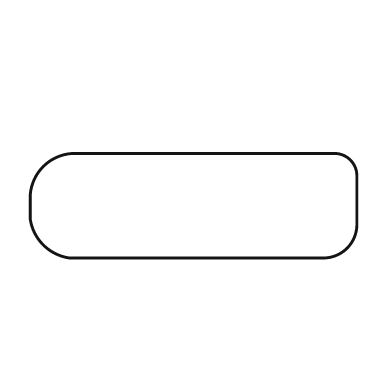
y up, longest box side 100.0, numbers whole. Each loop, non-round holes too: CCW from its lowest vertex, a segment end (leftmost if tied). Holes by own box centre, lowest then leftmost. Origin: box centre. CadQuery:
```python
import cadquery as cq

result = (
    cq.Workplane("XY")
    .moveTo(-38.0, -16.0)
    .lineTo(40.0, -16.0)
    .threePointArc((47.0, -13.0), (50.0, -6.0))
    .lineTo(50.0, 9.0)
    .threePointArc((48.0, 14.0), (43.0, 16.0))
    .lineTo(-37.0, 16.0)
    .threePointArc((-46.0, 12.0), (-50.0, 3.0))
    .lineTo(-50.0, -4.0)
    .threePointArc((-46.0, -12.0), (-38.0, -16.0))
    .close()
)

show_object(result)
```